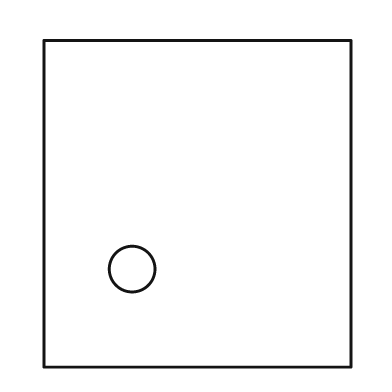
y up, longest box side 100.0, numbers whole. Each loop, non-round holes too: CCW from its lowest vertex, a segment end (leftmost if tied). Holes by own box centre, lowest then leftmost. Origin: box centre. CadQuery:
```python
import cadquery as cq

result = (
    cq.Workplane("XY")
    .moveTo(-47.0, -50.0)
    .lineTo(47.0, -50.0)
    .lineTo(47.0, 50.0)
    .lineTo(-47.0, 50.0)
    .close()
    .moveTo(-20.0, -20.0)
    .circle(7.0)
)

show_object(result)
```